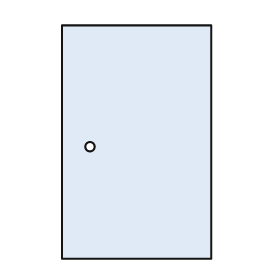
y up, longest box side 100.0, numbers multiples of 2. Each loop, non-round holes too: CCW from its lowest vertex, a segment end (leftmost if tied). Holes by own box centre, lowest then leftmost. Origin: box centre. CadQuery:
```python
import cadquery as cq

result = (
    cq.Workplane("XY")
    .moveTo(-32.0, -50.0)
    .lineTo(32.0, -50.0)
    .lineTo(32.0, 50.0)
    .lineTo(-32.0, 50.0)
    .close()
    .moveTo(-20.0, -2.0)
    .circle(2.0)
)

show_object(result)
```